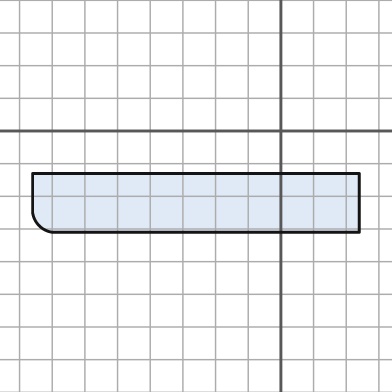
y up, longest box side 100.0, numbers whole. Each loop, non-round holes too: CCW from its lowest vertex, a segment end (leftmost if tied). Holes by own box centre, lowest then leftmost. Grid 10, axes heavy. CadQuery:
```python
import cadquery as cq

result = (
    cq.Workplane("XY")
    .moveTo(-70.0, -31.0)
    .lineTo(24.0, -31.0)
    .lineTo(24.0, -13.0)
    .lineTo(-76.0, -13.0)
    .lineTo(-76.0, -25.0)
    .threePointArc((-74.0, -29.0), (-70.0, -31.0))
    .close()
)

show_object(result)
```